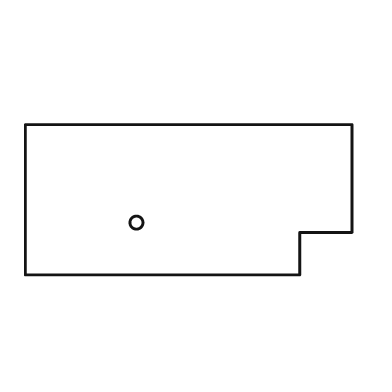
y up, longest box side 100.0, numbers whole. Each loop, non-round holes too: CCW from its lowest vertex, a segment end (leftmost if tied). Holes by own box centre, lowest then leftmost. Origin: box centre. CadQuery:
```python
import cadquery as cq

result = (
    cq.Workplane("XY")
    .moveTo(-50.0, -23.0)
    .lineTo(34.0, -23.0)
    .lineTo(34.0, -10.0)
    .lineTo(50.0, -10.0)
    .lineTo(50.0, 23.0)
    .lineTo(-50.0, 23.0)
    .close()
    .moveTo(-16.0, -7.0)
    .circle(2.0)
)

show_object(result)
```